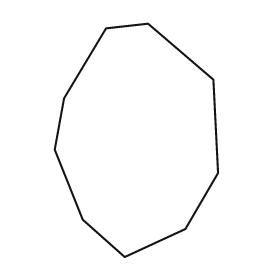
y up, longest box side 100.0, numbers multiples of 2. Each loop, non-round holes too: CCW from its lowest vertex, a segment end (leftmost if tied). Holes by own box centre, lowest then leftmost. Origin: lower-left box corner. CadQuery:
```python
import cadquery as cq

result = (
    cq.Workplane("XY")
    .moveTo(30.0, 0.0)
    .lineTo(56.0, 12.0)
    .lineTo(70.0, 36.0)
    .lineTo(68.0, 76.0)
    .lineTo(40.0, 100.0)
    .lineTo(22.0, 98.0)
    .lineTo(4.0, 68.0)
    .lineTo(0.0, 46.0)
    .lineTo(12.0, 16.0)
    .close()
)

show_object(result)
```